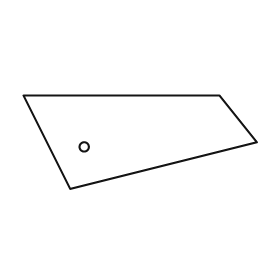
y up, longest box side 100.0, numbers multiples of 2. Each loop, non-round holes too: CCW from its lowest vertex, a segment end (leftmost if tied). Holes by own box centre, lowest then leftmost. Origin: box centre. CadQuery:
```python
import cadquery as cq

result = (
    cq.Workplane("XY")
    .moveTo(-30.0, -20.0)
    .lineTo(50.0, 0.0)
    .lineTo(34.0, 20.0)
    .lineTo(-50.0, 20.0)
    .close()
    .moveTo(-24.0, -2.0)
    .circle(2.0)
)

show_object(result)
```